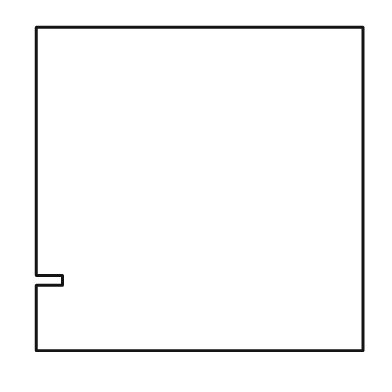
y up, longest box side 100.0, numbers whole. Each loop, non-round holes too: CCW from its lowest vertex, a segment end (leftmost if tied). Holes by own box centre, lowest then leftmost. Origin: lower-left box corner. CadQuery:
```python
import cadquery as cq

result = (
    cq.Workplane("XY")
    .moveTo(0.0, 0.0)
    .lineTo(100.0, 0.0)
    .lineTo(100.0, 99.0)
    .lineTo(0.0, 99.0)
    .lineTo(0.0, 23.0)
    .lineTo(8.0, 23.0)
    .lineTo(8.0, 20.0)
    .lineTo(0.0, 20.0)
    .close()
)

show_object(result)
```